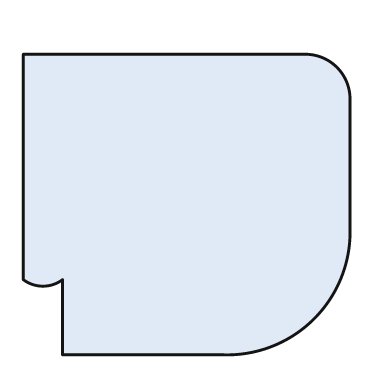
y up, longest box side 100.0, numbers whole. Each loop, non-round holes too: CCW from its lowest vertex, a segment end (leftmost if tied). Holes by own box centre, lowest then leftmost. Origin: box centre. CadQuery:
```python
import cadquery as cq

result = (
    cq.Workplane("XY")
    .moveTo(-38.0, -46.0)
    .lineTo(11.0, -46.0)
    .threePointArc((39.0, -35.0), (50.0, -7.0))
    .lineTo(50.0, 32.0)
    .threePointArc((46.0, 42.0), (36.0, 46.0))
    .lineTo(-50.0, 46.0)
    .lineTo(-50.0, -23.0)
    .threePointArc((-44.0, -25.0), (-38.0, -23.0))
    .close()
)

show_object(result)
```